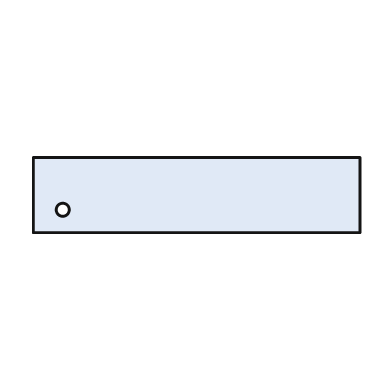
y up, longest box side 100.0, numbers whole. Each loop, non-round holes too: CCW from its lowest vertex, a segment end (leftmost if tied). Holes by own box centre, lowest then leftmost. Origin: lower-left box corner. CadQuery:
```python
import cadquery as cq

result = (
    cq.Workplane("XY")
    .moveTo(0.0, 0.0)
    .lineTo(100.0, 0.0)
    .lineTo(100.0, 23.0)
    .lineTo(0.0, 23.0)
    .close()
    .moveTo(9.0, 7.0)
    .circle(2.0)
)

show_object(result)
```